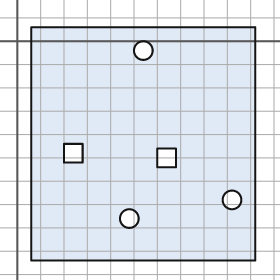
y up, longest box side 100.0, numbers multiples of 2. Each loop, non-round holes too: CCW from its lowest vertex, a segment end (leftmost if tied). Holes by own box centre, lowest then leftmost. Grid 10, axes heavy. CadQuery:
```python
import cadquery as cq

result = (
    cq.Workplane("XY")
    .moveTo(6.0, -94.0)
    .lineTo(102.0, -94.0)
    .lineTo(102.0, 6.0)
    .lineTo(6.0, 6.0)
    .close()
    .moveTo(48.0, -76.0)
    .circle(4.0)
    .moveTo(92.0, -68.0)
    .circle(4.0)
    .moveTo(60.0, -54.0)
    .lineTo(68.0, -54.0)
    .lineTo(68.0, -46.0)
    .lineTo(60.0, -46.0)
    .close()
    .moveTo(20.0, -52.0)
    .lineTo(28.0, -52.0)
    .lineTo(28.0, -44.0)
    .lineTo(20.0, -44.0)
    .close()
    .moveTo(54.0, -4.0)
    .circle(4.0)
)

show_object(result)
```